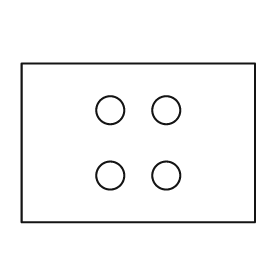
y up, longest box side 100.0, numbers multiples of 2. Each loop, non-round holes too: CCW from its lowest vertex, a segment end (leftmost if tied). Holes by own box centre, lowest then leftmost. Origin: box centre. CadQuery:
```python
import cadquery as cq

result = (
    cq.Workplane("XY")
    .moveTo(-50.0, -34.0)
    .lineTo(50.0, -34.0)
    .lineTo(50.0, 34.0)
    .lineTo(-50.0, 34.0)
    .close()
    .moveTo(-12.0, -14.0)
    .circle(6.0)
    .moveTo(12.0, -14.0)
    .circle(6.0)
    .moveTo(-12.0, 14.0)
    .circle(6.0)
    .moveTo(12.0, 14.0)
    .circle(6.0)
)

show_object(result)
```